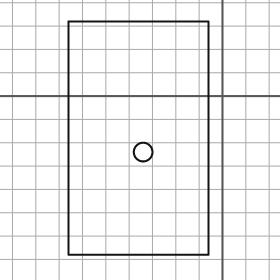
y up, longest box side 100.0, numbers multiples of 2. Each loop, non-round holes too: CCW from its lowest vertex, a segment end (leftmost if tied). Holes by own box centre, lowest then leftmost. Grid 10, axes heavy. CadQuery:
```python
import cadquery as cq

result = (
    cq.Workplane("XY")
    .moveTo(-66.0, -68.0)
    .lineTo(-6.0, -68.0)
    .lineTo(-6.0, 32.0)
    .lineTo(-66.0, 32.0)
    .close()
    .moveTo(-34.0, -24.0)
    .circle(4.0)
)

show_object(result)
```